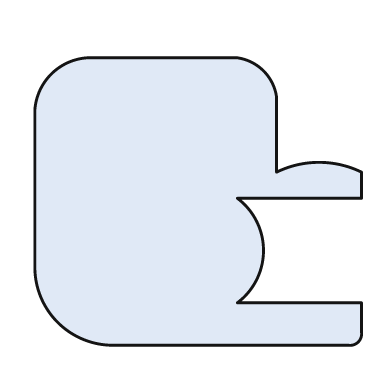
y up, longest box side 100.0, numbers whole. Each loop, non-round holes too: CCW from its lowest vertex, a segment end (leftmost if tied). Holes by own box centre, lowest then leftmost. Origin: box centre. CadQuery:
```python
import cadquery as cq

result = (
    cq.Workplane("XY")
    .moveTo(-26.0, -44.0)
    .lineTo(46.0, -44.0)
    .threePointArc((49.0, -43.0), (50.0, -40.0))
    .lineTo(50.0, -31.0)
    .lineTo(12.0, -31.0)
    .threePointArc((20.0, -15.0), (12.0, 1.0))
    .lineTo(50.0, 1.0)
    .lineTo(50.0, 9.0)
    .threePointArc((37.0, 12.0), (24.0, 9.0))
    .lineTo(24.0, 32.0)
    .threePointArc((20.0, 40.0), (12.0, 44.0))
    .lineTo(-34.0, 44.0)
    .threePointArc((-45.0, 39.0), (-50.0, 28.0))
    .lineTo(-50.0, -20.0)
    .threePointArc((-43.0, -37.0), (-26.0, -44.0))
    .close()
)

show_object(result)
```